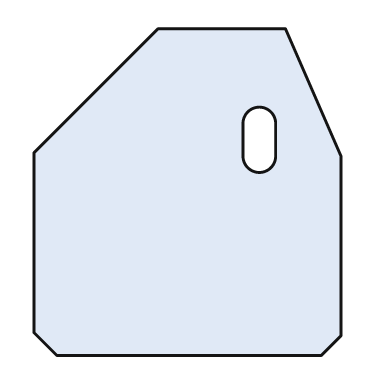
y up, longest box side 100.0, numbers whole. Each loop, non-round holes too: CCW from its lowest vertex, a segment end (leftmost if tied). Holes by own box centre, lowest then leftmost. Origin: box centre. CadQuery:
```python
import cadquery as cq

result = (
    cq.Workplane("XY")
    .moveTo(-40.0, -50.0)
    .lineTo(41.0, -50.0)
    .lineTo(47.0, -44.0)
    .lineTo(47.0, 11.0)
    .lineTo(30.0, 50.0)
    .lineTo(-9.0, 50.0)
    .lineTo(-47.0, 12.0)
    .lineTo(-47.0, -43.0)
    .close()
    .moveTo(17.0, 11.0)
    .threePointArc((22.0, 6.0), (27.0, 11.0))
    .lineTo(27.0, 21.0)
    .threePointArc((22.0, 26.0), (17.0, 21.0))
    .close()
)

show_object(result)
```